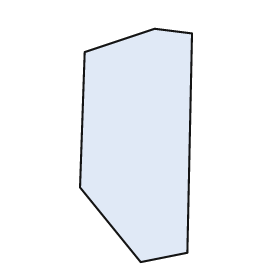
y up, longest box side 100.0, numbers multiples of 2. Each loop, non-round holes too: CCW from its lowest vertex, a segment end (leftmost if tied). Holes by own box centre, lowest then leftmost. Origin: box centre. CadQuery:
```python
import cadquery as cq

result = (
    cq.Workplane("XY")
    .moveTo(2.0, -50.0)
    .lineTo(22.0, -46.0)
    .lineTo(24.0, 48.0)
    .lineTo(8.0, 50.0)
    .lineTo(-22.0, 40.0)
    .lineTo(-24.0, -18.0)
    .close()
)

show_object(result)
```